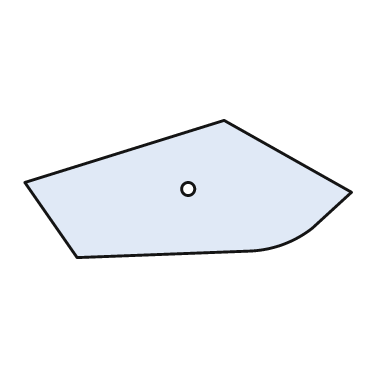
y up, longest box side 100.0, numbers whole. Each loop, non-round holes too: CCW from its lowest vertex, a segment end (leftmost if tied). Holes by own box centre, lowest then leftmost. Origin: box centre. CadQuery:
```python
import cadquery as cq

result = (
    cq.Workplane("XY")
    .moveTo(-34.0, -21.0)
    .lineTo(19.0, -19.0)
    .threePointArc((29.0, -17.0), (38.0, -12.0))
    .lineTo(50.0, -1.0)
    .lineTo(11.0, 21.0)
    .lineTo(-50.0, 2.0)
    .close()
    .moveTo(0.0, 0.0)
    .circle(2.0)
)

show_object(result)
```